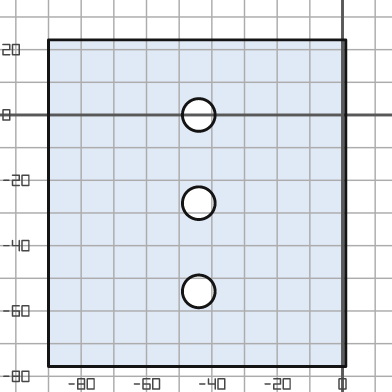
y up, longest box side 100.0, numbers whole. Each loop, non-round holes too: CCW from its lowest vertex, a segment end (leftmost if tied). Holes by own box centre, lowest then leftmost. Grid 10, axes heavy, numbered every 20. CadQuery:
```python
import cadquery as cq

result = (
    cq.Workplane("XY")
    .moveTo(-90.0, -77.0)
    .lineTo(1.0, -77.0)
    .lineTo(1.0, 23.0)
    .lineTo(-90.0, 23.0)
    .close()
    .moveTo(-44.0, -54.0)
    .circle(5.0)
    .moveTo(-44.0, -27.0)
    .circle(5.0)
    .moveTo(-44.0, 0.0)
    .circle(5.0)
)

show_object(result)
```